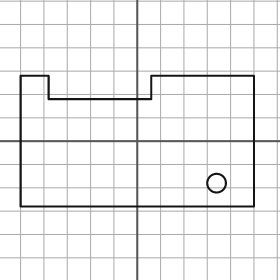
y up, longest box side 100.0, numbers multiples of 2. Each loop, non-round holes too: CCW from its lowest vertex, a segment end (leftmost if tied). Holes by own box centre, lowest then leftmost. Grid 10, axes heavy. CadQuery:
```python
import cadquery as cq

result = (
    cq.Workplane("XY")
    .moveTo(-50.0, -28.0)
    .lineTo(50.0, -28.0)
    .lineTo(50.0, 28.0)
    .lineTo(6.0, 28.0)
    .lineTo(6.0, 18.0)
    .lineTo(-38.0, 18.0)
    .lineTo(-38.0, 28.0)
    .lineTo(-50.0, 28.0)
    .close()
    .moveTo(34.0, -18.0)
    .circle(4.0)
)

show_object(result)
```